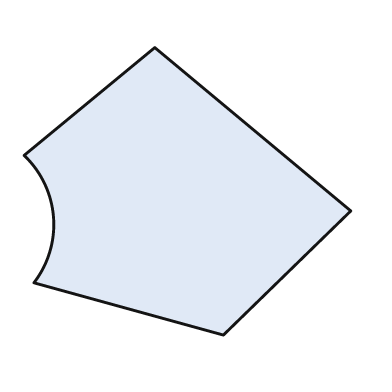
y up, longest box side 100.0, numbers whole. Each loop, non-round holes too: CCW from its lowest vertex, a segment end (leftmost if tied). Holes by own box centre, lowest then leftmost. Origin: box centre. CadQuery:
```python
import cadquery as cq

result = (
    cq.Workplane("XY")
    .moveTo(11.0, -44.0)
    .lineTo(50.0, -6.0)
    .lineTo(-10.0, 44.0)
    .lineTo(-50.0, 11.0)
    .threePointArc((-41.0, -8.0), (-47.0, -28.0))
    .close()
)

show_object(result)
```